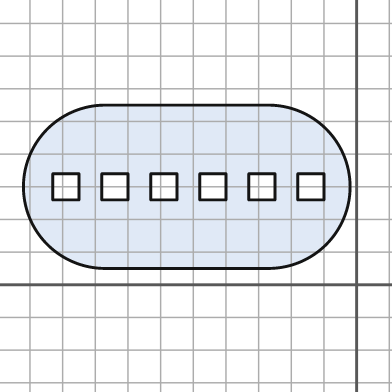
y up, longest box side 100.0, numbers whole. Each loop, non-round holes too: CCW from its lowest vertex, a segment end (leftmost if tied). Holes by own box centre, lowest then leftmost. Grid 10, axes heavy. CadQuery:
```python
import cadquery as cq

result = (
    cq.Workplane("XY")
    .moveTo(-77.0, 5.0)
    .lineTo(-27.0, 5.0)
    .threePointArc((-2.0, 30.0), (-27.0, 55.0))
    .lineTo(-77.0, 55.0)
    .threePointArc((-102.0, 30.0), (-77.0, 5.0))
    .close()
    .moveTo(-93.0, 26.0)
    .lineTo(-85.0, 26.0)
    .lineTo(-85.0, 34.0)
    .lineTo(-93.0, 34.0)
    .close()
    .moveTo(-78.0, 26.0)
    .lineTo(-70.0, 26.0)
    .lineTo(-70.0, 34.0)
    .lineTo(-78.0, 34.0)
    .close()
    .moveTo(-63.0, 26.0)
    .lineTo(-55.0, 26.0)
    .lineTo(-55.0, 34.0)
    .lineTo(-63.0, 34.0)
    .close()
    .moveTo(-48.0, 26.0)
    .lineTo(-40.0, 26.0)
    .lineTo(-40.0, 34.0)
    .lineTo(-48.0, 34.0)
    .close()
    .moveTo(-33.0, 26.0)
    .lineTo(-25.0, 26.0)
    .lineTo(-25.0, 34.0)
    .lineTo(-33.0, 34.0)
    .close()
    .moveTo(-18.0, 26.0)
    .lineTo(-10.0, 26.0)
    .lineTo(-10.0, 34.0)
    .lineTo(-18.0, 34.0)
    .close()
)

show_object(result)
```